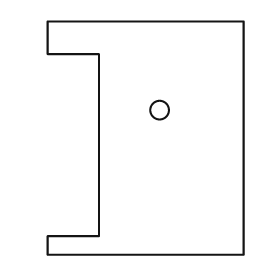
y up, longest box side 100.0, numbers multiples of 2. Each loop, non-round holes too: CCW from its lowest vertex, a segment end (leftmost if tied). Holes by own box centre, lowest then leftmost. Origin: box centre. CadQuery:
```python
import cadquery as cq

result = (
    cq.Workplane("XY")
    .moveTo(-42.0, -50.0)
    .lineTo(42.0, -50.0)
    .lineTo(42.0, 50.0)
    .lineTo(-42.0, 50.0)
    .lineTo(-42.0, 36.0)
    .lineTo(-20.0, 36.0)
    .lineTo(-20.0, -42.0)
    .lineTo(-42.0, -42.0)
    .close()
    .moveTo(6.0, 12.0)
    .circle(4.0)
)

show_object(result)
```